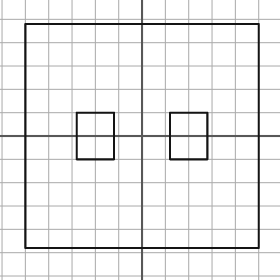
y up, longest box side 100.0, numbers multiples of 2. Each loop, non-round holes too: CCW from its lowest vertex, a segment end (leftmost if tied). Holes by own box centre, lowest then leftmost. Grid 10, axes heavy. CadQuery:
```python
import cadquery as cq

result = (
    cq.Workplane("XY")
    .moveTo(-50.0, -48.0)
    .lineTo(50.0, -48.0)
    .lineTo(50.0, 48.0)
    .lineTo(-50.0, 48.0)
    .close()
    .moveTo(-28.0, -10.0)
    .lineTo(-12.0, -10.0)
    .lineTo(-12.0, 10.0)
    .lineTo(-28.0, 10.0)
    .close()
    .moveTo(12.0, -10.0)
    .lineTo(28.0, -10.0)
    .lineTo(28.0, 10.0)
    .lineTo(12.0, 10.0)
    .close()
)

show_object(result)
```